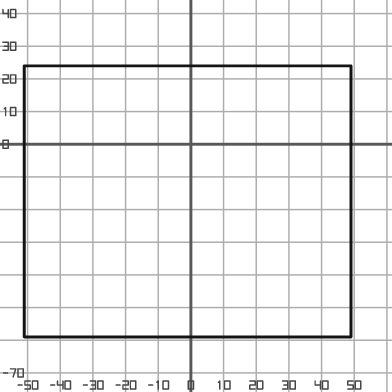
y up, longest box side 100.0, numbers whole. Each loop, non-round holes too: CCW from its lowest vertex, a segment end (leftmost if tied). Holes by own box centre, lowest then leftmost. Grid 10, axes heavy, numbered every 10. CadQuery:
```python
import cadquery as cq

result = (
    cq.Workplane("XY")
    .moveTo(-51.0, -59.0)
    .lineTo(49.0, -59.0)
    .lineTo(49.0, 24.0)
    .lineTo(-51.0, 24.0)
    .close()
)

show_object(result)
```